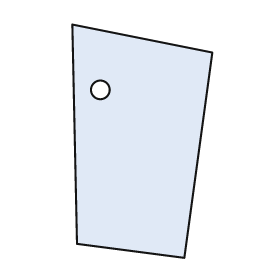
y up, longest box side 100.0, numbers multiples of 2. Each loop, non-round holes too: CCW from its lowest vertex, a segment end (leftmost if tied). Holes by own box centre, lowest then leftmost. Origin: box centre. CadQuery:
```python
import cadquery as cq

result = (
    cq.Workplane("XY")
    .moveTo(18.0, -50.0)
    .lineTo(30.0, 38.0)
    .lineTo(-30.0, 50.0)
    .lineTo(-28.0, -44.0)
    .close()
    .moveTo(-18.0, 22.0)
    .circle(4.0)
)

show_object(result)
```